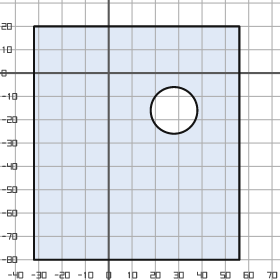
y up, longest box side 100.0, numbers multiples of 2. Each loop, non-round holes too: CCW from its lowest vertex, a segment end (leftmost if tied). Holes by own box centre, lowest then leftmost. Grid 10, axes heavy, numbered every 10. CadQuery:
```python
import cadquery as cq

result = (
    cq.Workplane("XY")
    .moveTo(-32.0, -80.0)
    .lineTo(56.0, -80.0)
    .lineTo(56.0, 20.0)
    .lineTo(-32.0, 20.0)
    .close()
    .moveTo(28.0, -16.0)
    .circle(10.0)
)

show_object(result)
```